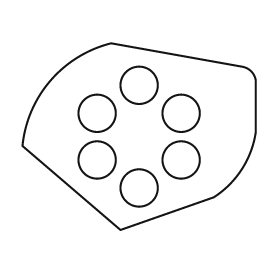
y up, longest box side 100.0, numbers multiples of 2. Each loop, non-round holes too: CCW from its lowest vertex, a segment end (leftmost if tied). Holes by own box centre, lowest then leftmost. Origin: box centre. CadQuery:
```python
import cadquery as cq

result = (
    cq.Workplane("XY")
    .moveTo(-8.0, -40.0)
    .lineTo(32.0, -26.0)
    .threePointArc((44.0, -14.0), (50.0, 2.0))
    .lineTo(50.0, 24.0)
    .threePointArc((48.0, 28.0), (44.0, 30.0))
    .lineTo(-12.0, 40.0)
    .threePointArc((-38.0, 24.0), (-50.0, -4.0))
    .close()
    .moveTo(0.0, -22.0)
    .circle(8.0)
    .moveTo(-18.0, -10.0)
    .circle(8.0)
    .moveTo(18.0, -10.0)
    .circle(8.0)
    .moveTo(-18.0, 10.0)
    .circle(8.0)
    .moveTo(18.0, 10.0)
    .circle(8.0)
    .moveTo(0.0, 22.0)
    .circle(8.0)
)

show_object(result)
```